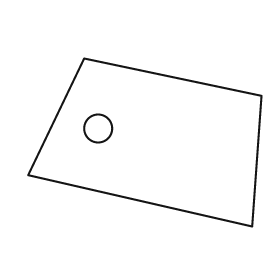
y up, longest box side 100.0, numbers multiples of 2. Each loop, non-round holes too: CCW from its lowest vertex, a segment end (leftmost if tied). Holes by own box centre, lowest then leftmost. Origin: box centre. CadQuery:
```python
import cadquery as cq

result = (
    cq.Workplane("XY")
    .moveTo(46.0, -36.0)
    .lineTo(50.0, 20.0)
    .lineTo(-26.0, 36.0)
    .lineTo(-50.0, -14.0)
    .close()
    .moveTo(-20.0, 6.0)
    .circle(6.0)
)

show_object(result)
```